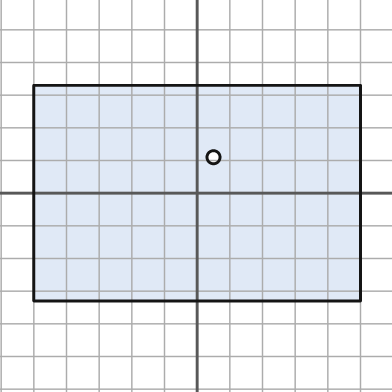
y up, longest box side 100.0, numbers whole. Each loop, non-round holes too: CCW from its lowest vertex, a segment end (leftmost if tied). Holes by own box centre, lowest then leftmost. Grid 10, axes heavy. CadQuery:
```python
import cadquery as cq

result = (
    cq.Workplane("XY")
    .moveTo(-50.0, -33.0)
    .lineTo(50.0, -33.0)
    .lineTo(50.0, 33.0)
    .lineTo(-50.0, 33.0)
    .close()
    .moveTo(5.0, 11.0)
    .circle(2.0)
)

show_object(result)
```